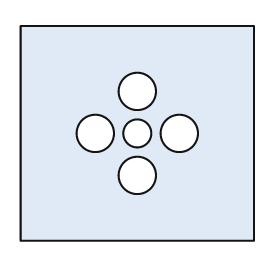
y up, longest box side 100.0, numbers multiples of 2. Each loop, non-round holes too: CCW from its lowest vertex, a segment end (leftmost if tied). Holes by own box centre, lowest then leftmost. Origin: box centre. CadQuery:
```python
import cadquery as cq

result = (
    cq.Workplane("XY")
    .moveTo(-50.0, -46.0)
    .lineTo(50.0, -46.0)
    .lineTo(50.0, 46.0)
    .lineTo(-50.0, 46.0)
    .close()
    .moveTo(0.0, -18.0)
    .circle(8.0)
    .moveTo(-18.0, 0.0)
    .circle(8.0)
    .moveTo(0.0, 0.0)
    .circle(6.0)
    .moveTo(18.0, 0.0)
    .circle(8.0)
    .moveTo(0.0, 18.0)
    .circle(8.0)
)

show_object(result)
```